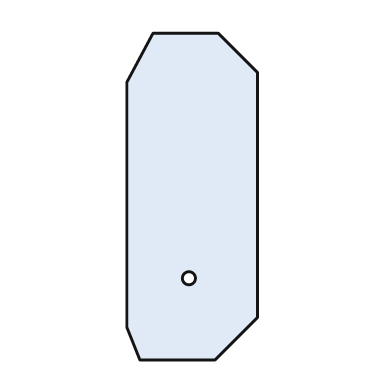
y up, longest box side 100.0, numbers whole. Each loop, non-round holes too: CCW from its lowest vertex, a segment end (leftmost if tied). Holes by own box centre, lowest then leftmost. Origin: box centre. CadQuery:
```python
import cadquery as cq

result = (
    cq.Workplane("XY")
    .moveTo(-16.0, -50.0)
    .lineTo(7.0, -50.0)
    .lineTo(20.0, -37.0)
    .lineTo(20.0, 38.0)
    .lineTo(8.0, 50.0)
    .lineTo(-12.0, 50.0)
    .lineTo(-20.0, 35.0)
    .lineTo(-20.0, -40.0)
    .close()
    .moveTo(-1.0, -25.0)
    .circle(2.0)
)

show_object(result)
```